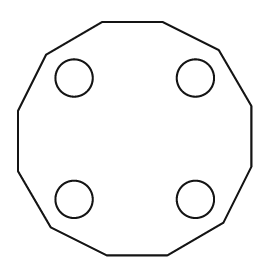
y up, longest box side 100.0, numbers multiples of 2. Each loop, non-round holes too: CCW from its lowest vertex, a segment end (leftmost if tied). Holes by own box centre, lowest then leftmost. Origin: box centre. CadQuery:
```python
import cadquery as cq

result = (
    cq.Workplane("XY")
    .moveTo(-12.0, -50.0)
    .lineTo(14.0, -50.0)
    .lineTo(38.0, -36.0)
    .lineTo(50.0, -12.0)
    .lineTo(50.0, 14.0)
    .lineTo(36.0, 38.0)
    .lineTo(12.0, 50.0)
    .lineTo(-14.0, 50.0)
    .lineTo(-38.0, 36.0)
    .lineTo(-50.0, 12.0)
    .lineTo(-50.0, -14.0)
    .lineTo(-36.0, -38.0)
    .close()
    .moveTo(-26.0, -26.0)
    .circle(8.0)
    .moveTo(26.0, -26.0)
    .circle(8.0)
    .moveTo(-26.0, 26.0)
    .circle(8.0)
    .moveTo(26.0, 26.0)
    .circle(8.0)
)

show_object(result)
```